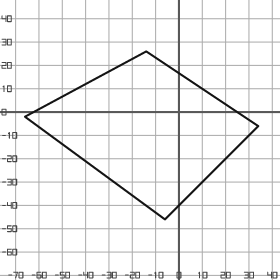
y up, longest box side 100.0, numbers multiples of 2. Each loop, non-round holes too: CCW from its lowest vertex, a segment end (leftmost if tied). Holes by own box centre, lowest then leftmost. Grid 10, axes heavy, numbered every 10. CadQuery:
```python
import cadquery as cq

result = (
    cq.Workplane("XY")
    .moveTo(-6.0, -46.0)
    .lineTo(34.0, -6.0)
    .lineTo(-14.0, 26.0)
    .lineTo(-66.0, -2.0)
    .close()
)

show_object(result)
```